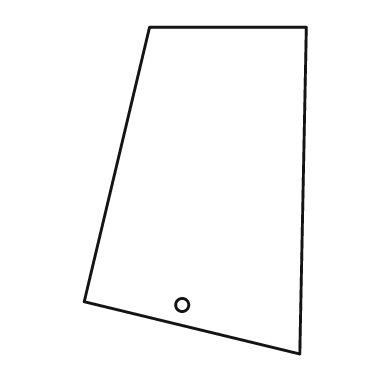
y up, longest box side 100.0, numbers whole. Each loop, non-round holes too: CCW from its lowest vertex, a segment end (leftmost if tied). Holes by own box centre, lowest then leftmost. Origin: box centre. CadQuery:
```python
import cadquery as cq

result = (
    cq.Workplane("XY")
    .moveTo(32.0, -50.0)
    .lineTo(34.0, 50.0)
    .lineTo(-14.0, 50.0)
    .lineTo(-34.0, -34.0)
    .close()
    .moveTo(-4.0, -35.0)
    .circle(2.0)
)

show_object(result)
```